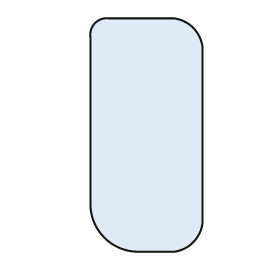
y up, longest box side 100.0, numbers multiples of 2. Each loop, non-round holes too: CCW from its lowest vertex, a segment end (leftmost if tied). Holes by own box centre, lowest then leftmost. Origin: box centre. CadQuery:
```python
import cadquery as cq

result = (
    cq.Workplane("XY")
    .moveTo(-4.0, -50.0)
    .lineTo(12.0, -50.0)
    .threePointArc((20.0, -46.0), (24.0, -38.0))
    .lineTo(24.0, 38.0)
    .threePointArc((20.0, 46.0), (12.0, 50.0))
    .lineTo(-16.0, 50.0)
    .threePointArc((-22.0, 48.0), (-24.0, 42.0))
    .lineTo(-24.0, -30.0)
    .threePointArc((-18.0, -44.0), (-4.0, -50.0))
    .close()
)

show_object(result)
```